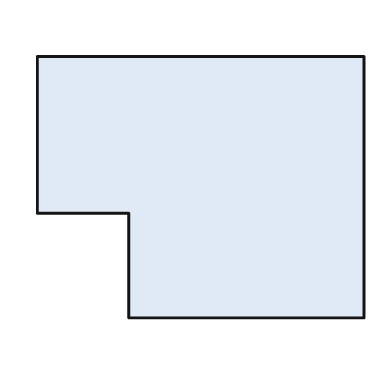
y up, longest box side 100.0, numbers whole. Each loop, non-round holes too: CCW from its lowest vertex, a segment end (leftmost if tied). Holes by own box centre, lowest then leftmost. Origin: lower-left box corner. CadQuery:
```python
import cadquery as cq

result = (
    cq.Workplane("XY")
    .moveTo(28.0, 0.0)
    .lineTo(100.0, 0.0)
    .lineTo(100.0, 80.0)
    .lineTo(0.0, 80.0)
    .lineTo(0.0, 32.0)
    .lineTo(28.0, 32.0)
    .close()
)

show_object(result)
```